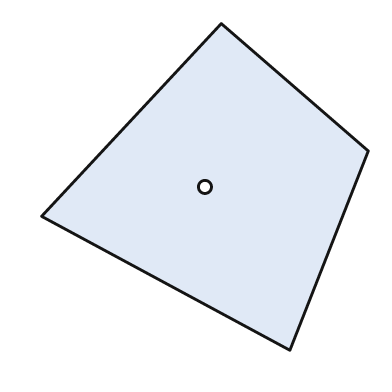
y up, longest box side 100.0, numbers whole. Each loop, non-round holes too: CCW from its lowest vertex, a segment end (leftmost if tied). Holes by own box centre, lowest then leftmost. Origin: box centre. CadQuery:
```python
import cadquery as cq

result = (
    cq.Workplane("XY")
    .moveTo(26.0, -50.0)
    .lineTo(50.0, 11.0)
    .lineTo(5.0, 50.0)
    .lineTo(-50.0, -9.0)
    .close()
    .moveTo(0.0, 0.0)
    .circle(2.0)
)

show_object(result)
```